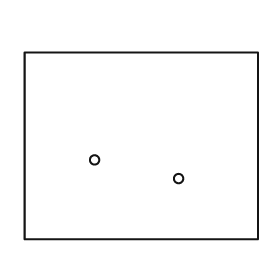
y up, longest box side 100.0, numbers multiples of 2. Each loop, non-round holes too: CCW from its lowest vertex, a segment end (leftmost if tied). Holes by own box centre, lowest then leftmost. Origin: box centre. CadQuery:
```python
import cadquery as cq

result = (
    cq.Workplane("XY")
    .moveTo(-50.0, -40.0)
    .lineTo(50.0, -40.0)
    .lineTo(50.0, 40.0)
    .lineTo(-50.0, 40.0)
    .close()
    .moveTo(16.0, -14.0)
    .circle(2.0)
    .moveTo(-20.0, -6.0)
    .circle(2.0)
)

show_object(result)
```